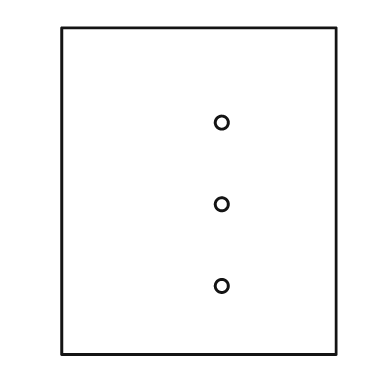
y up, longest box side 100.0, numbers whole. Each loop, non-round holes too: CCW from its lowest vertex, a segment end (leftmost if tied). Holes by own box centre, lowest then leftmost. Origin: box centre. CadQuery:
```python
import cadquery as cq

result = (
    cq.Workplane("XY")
    .moveTo(-42.0, -50.0)
    .lineTo(42.0, -50.0)
    .lineTo(42.0, 50.0)
    .lineTo(-42.0, 50.0)
    .close()
    .moveTo(7.0, -29.0)
    .circle(2.0)
    .moveTo(7.0, -4.0)
    .circle(2.0)
    .moveTo(7.0, 21.0)
    .circle(2.0)
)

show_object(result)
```